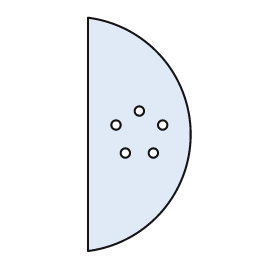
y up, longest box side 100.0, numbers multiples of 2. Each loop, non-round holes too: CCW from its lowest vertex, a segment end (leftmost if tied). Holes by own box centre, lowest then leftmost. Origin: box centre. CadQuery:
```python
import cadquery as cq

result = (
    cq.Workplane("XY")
    .moveTo(-22.0, -50.0)
    .threePointArc((22.0, 0.0), (-22.0, 50.0))
    .close()
    .moveTo(-6.0, -8.0)
    .circle(2.0)
    .moveTo(6.0, -8.0)
    .circle(2.0)
    .moveTo(-10.0, 4.0)
    .circle(2.0)
    .moveTo(10.0, 4.0)
    .circle(2.0)
    .moveTo(0.0, 10.0)
    .circle(2.0)
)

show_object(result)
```